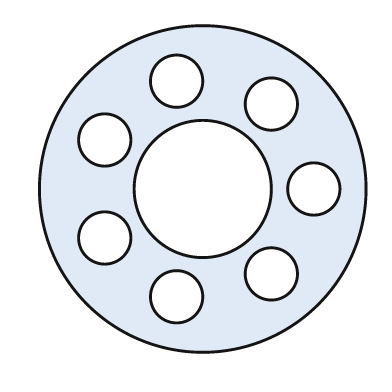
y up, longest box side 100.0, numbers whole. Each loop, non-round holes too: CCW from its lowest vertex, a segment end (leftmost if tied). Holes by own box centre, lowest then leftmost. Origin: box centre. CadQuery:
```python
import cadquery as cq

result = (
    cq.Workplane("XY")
    .moveTo(0.0, 0.0)
    .circle(50.0)
    .moveTo(-8.0, -33.0)
    .circle(8.0)
    .moveTo(21.0, -26.0)
    .circle(8.0)
    .moveTo(-30.0, -15.0)
    .circle(8.0)
    .moveTo(0.0, 0.0)
    .circle(21.0)
    .moveTo(34.0, 0.0)
    .circle(8.0)
    .moveTo(-30.0, 15.0)
    .circle(8.0)
    .moveTo(21.0, 26.0)
    .circle(8.0)
    .moveTo(-8.0, 33.0)
    .circle(8.0)
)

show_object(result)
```